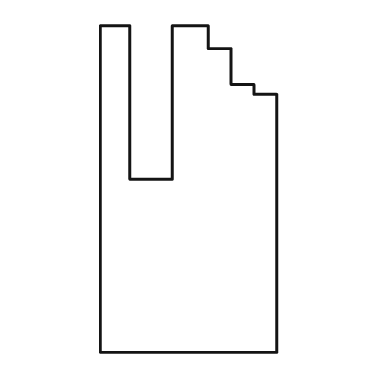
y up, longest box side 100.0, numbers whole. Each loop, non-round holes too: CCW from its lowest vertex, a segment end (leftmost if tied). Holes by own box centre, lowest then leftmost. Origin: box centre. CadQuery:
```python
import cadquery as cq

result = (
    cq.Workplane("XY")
    .moveTo(-27.0, -50.0)
    .lineTo(27.0, -50.0)
    .lineTo(27.0, 29.0)
    .lineTo(20.0, 29.0)
    .lineTo(20.0, 32.0)
    .lineTo(13.0, 32.0)
    .lineTo(13.0, 43.0)
    .lineTo(6.0, 43.0)
    .lineTo(6.0, 50.0)
    .lineTo(-5.0, 50.0)
    .lineTo(-5.0, 3.0)
    .lineTo(-18.0, 3.0)
    .lineTo(-18.0, 50.0)
    .lineTo(-27.0, 50.0)
    .close()
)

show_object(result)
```